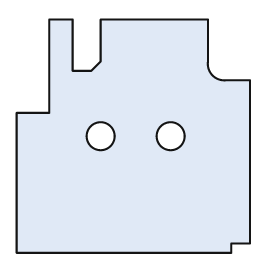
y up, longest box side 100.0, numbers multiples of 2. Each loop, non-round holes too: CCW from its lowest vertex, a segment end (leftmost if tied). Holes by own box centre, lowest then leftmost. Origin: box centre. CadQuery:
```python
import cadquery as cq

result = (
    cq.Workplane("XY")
    .moveTo(-50.0, -50.0)
    .lineTo(42.0, -50.0)
    .lineTo(42.0, -46.0)
    .lineTo(50.0, -46.0)
    .lineTo(50.0, 24.0)
    .lineTo(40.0, 24.0)
    .threePointArc((34.0, 26.0), (32.0, 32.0))
    .lineTo(32.0, 50.0)
    .lineTo(-14.0, 50.0)
    .lineTo(-14.0, 32.0)
    .lineTo(-18.0, 28.0)
    .lineTo(-26.0, 28.0)
    .lineTo(-26.0, 50.0)
    .lineTo(-36.0, 50.0)
    .lineTo(-36.0, 10.0)
    .lineTo(-50.0, 10.0)
    .close()
    .moveTo(-14.0, 0.0)
    .circle(6.0)
    .moveTo(16.0, 0.0)
    .circle(6.0)
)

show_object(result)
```